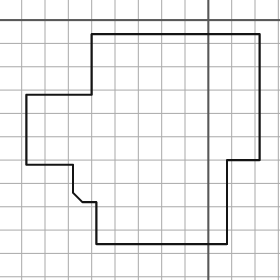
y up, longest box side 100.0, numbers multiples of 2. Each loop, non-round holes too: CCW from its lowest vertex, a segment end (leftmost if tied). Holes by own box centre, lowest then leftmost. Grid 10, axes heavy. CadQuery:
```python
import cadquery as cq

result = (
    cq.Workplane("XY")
    .moveTo(-48.0, -96.0)
    .lineTo(8.0, -96.0)
    .lineTo(8.0, -60.0)
    .lineTo(22.0, -60.0)
    .lineTo(22.0, -6.0)
    .lineTo(-50.0, -6.0)
    .lineTo(-50.0, -32.0)
    .lineTo(-78.0, -32.0)
    .lineTo(-78.0, -62.0)
    .lineTo(-58.0, -62.0)
    .lineTo(-58.0, -74.0)
    .lineTo(-54.0, -78.0)
    .lineTo(-48.0, -78.0)
    .close()
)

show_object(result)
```